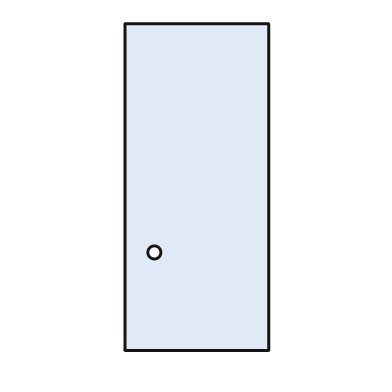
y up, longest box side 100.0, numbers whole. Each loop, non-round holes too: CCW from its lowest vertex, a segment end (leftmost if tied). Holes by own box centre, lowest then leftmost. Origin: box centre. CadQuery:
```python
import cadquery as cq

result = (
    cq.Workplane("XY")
    .moveTo(-22.0, -50.0)
    .lineTo(22.0, -50.0)
    .lineTo(22.0, 50.0)
    .lineTo(-22.0, 50.0)
    .close()
    .moveTo(-13.0, -20.0)
    .circle(2.0)
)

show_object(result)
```